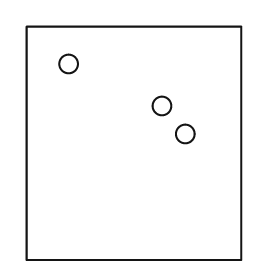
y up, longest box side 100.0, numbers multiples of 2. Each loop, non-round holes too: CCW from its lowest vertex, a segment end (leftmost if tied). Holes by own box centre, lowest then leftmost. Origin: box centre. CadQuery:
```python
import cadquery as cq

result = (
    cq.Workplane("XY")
    .moveTo(-46.0, -50.0)
    .lineTo(46.0, -50.0)
    .lineTo(46.0, 50.0)
    .lineTo(-46.0, 50.0)
    .close()
    .moveTo(22.0, 4.0)
    .circle(4.0)
    .moveTo(12.0, 16.0)
    .circle(4.0)
    .moveTo(-28.0, 34.0)
    .circle(4.0)
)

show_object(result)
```